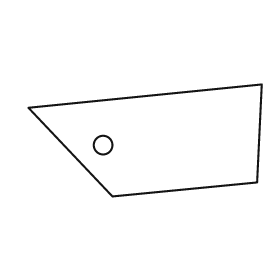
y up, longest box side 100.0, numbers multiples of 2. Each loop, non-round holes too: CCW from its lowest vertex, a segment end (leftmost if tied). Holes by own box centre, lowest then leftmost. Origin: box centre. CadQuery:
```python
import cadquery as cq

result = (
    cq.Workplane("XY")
    .moveTo(-14.0, -24.0)
    .lineTo(48.0, -18.0)
    .lineTo(50.0, 24.0)
    .lineTo(-50.0, 14.0)
    .close()
    .moveTo(-18.0, -2.0)
    .circle(4.0)
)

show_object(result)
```